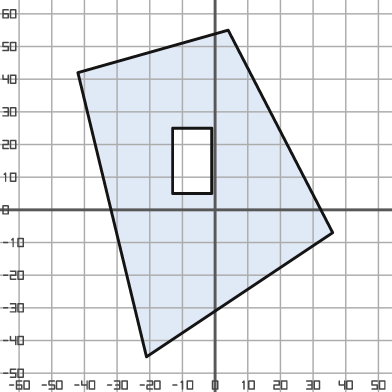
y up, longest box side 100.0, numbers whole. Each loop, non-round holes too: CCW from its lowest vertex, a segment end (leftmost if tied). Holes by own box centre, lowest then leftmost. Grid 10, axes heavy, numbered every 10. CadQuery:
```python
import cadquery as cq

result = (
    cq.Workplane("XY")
    .moveTo(-21.0, -45.0)
    .lineTo(36.0, -7.0)
    .lineTo(4.0, 55.0)
    .lineTo(-42.0, 42.0)
    .close()
    .moveTo(-13.0, 5.0)
    .lineTo(-1.0, 5.0)
    .lineTo(-1.0, 25.0)
    .lineTo(-13.0, 25.0)
    .close()
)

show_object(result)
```